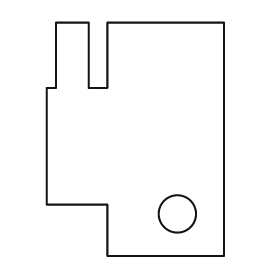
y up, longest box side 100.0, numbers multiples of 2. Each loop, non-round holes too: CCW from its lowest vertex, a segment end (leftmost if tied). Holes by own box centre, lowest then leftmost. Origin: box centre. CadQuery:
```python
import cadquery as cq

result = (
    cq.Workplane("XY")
    .moveTo(-12.0, -50.0)
    .lineTo(38.0, -50.0)
    .lineTo(38.0, 50.0)
    .lineTo(-12.0, 50.0)
    .lineTo(-12.0, 22.0)
    .lineTo(-20.0, 22.0)
    .lineTo(-20.0, 50.0)
    .lineTo(-34.0, 50.0)
    .lineTo(-34.0, 22.0)
    .lineTo(-38.0, 22.0)
    .lineTo(-38.0, -28.0)
    .lineTo(-12.0, -28.0)
    .close()
    .moveTo(18.0, -32.0)
    .circle(8.0)
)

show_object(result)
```